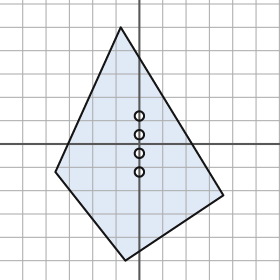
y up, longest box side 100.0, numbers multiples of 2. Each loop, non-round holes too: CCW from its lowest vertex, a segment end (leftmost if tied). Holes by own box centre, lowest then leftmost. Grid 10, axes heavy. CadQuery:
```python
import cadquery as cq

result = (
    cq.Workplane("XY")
    .moveTo(-6.0, -50.0)
    .lineTo(36.0, -22.0)
    .lineTo(-8.0, 50.0)
    .lineTo(-36.0, -12.0)
    .close()
    .moveTo(0.0, -12.0)
    .circle(2.0)
    .moveTo(0.0, -4.0)
    .circle(2.0)
    .moveTo(0.0, 4.0)
    .circle(2.0)
    .moveTo(0.0, 12.0)
    .circle(2.0)
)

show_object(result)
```